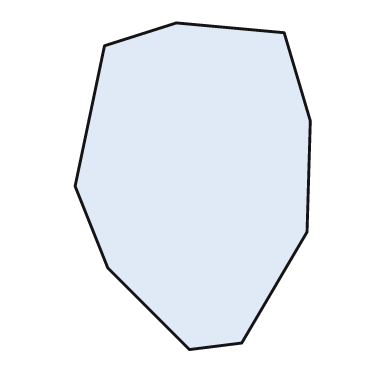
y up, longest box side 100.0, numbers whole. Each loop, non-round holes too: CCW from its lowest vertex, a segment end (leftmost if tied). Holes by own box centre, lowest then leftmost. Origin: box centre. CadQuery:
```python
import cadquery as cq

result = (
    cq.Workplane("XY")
    .moveTo(-1.0, -50.0)
    .lineTo(15.0, -48.0)
    .lineTo(35.0, -14.0)
    .lineTo(36.0, 20.0)
    .lineTo(28.0, 47.0)
    .lineTo(-5.0, 50.0)
    .lineTo(-27.0, 43.0)
    .lineTo(-36.0, 0.0)
    .lineTo(-26.0, -25.0)
    .close()
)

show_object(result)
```